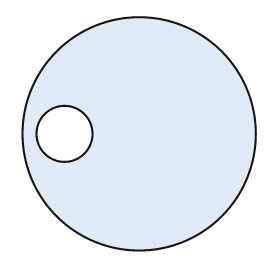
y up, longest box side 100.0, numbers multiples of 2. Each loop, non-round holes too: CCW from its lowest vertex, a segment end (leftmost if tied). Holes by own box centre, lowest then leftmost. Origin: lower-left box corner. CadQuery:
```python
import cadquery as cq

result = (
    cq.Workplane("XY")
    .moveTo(50.0, 50.0)
    .circle(50.0)
    .moveTo(18.0, 50.0)
    .circle(12.0)
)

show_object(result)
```